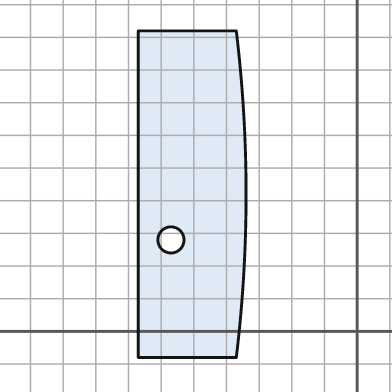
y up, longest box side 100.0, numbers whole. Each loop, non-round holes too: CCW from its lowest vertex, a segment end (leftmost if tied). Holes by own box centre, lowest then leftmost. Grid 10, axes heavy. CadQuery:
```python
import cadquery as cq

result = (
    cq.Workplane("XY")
    .moveTo(-67.0, -8.0)
    .lineTo(-37.0, -8.0)
    .threePointArc((-34.0, 42.0), (-37.0, 92.0))
    .lineTo(-67.0, 92.0)
    .close()
    .moveTo(-57.0, 28.0)
    .circle(4.0)
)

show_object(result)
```